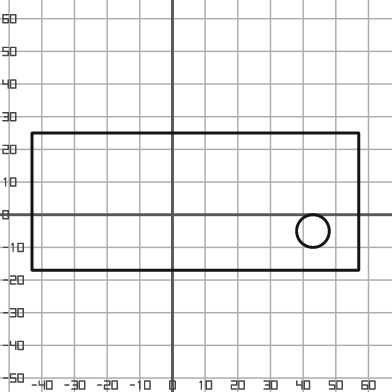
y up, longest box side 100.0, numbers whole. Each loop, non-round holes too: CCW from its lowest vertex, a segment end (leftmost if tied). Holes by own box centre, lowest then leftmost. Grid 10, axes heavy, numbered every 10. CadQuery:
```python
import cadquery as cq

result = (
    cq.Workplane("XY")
    .moveTo(-43.0, -17.0)
    .lineTo(57.0, -17.0)
    .lineTo(57.0, 25.0)
    .lineTo(-43.0, 25.0)
    .close()
    .moveTo(43.0, -5.0)
    .circle(5.0)
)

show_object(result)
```